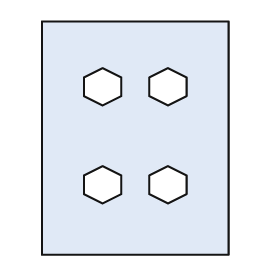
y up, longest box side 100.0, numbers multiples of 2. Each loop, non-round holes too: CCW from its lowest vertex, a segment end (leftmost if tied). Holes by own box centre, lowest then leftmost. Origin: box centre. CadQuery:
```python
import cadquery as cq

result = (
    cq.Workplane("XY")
    .moveTo(-40.0, -50.0)
    .lineTo(40.0, -50.0)
    .lineTo(40.0, 50.0)
    .lineTo(-40.0, 50.0)
    .close()
    .moveTo(-14.0, -28.0)
    .lineTo(-6.0, -24.0)
    .lineTo(-6.0, -16.0)
    .lineTo(-14.0, -12.0)
    .lineTo(-22.0, -16.0)
    .lineTo(-22.0, -24.0)
    .close()
    .moveTo(14.0, -28.0)
    .lineTo(22.0, -24.0)
    .lineTo(22.0, -16.0)
    .lineTo(14.0, -12.0)
    .lineTo(6.0, -16.0)
    .lineTo(6.0, -24.0)
    .close()
    .moveTo(-14.0, 14.0)
    .lineTo(-6.0, 18.0)
    .lineTo(-6.0, 26.0)
    .lineTo(-14.0, 30.0)
    .lineTo(-22.0, 26.0)
    .lineTo(-22.0, 18.0)
    .close()
    .moveTo(14.0, 14.0)
    .lineTo(22.0, 18.0)
    .lineTo(22.0, 26.0)
    .lineTo(14.0, 30.0)
    .lineTo(6.0, 26.0)
    .lineTo(6.0, 18.0)
    .close()
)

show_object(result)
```